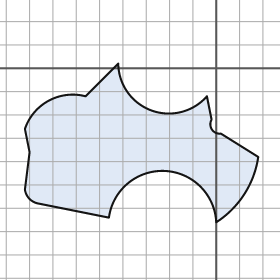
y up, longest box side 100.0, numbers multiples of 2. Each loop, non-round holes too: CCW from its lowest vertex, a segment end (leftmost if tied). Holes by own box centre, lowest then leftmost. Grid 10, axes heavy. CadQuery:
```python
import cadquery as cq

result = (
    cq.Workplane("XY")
    .moveTo(0.0, -66.0)
    .threePointArc((12.0, -54.0), (18.0, -38.0))
    .lineTo(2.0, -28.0)
    .threePointArc((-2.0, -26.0), (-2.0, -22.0))
    .lineTo(-4.0, -12.0)
    .threePointArc((-28.0, -18.0), (-42.0, 2.0))
    .lineTo(-56.0, -12.0)
    .threePointArc((-72.0, -14.0), (-82.0, -26.0))
    .lineTo(-80.0, -36.0)
    .lineTo(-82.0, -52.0)
    .threePointArc((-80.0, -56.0), (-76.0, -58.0))
    .lineTo(-46.0, -64.0)
    .threePointArc((-22.0, -44.0), (0.0, -66.0))
    .close()
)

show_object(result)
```